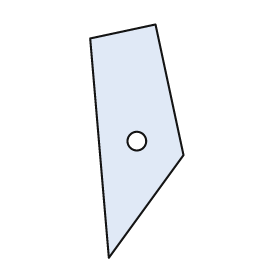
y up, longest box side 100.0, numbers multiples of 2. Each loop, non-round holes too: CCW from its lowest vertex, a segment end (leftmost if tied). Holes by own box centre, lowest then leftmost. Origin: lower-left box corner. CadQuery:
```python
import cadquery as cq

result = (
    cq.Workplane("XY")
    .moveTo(8.0, 0.0)
    .lineTo(40.0, 44.0)
    .lineTo(28.0, 100.0)
    .lineTo(0.0, 94.0)
    .close()
    .moveTo(20.0, 50.0)
    .circle(4.0)
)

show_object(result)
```